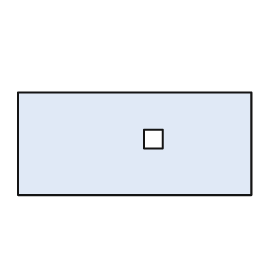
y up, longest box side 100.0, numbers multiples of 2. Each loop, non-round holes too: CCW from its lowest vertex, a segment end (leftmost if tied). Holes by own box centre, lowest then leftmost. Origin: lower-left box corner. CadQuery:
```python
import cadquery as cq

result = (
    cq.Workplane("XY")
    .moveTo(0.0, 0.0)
    .lineTo(100.0, 0.0)
    .lineTo(100.0, 44.0)
    .lineTo(0.0, 44.0)
    .close()
    .moveTo(54.0, 20.0)
    .lineTo(62.0, 20.0)
    .lineTo(62.0, 28.0)
    .lineTo(54.0, 28.0)
    .close()
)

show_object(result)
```